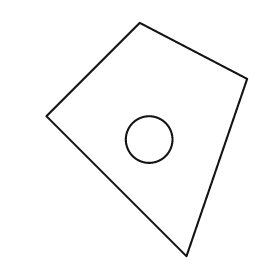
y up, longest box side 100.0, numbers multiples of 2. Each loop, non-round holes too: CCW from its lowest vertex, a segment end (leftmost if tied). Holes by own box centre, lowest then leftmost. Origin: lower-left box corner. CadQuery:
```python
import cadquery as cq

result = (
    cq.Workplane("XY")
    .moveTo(60.0, 0.0)
    .lineTo(86.0, 76.0)
    .lineTo(40.0, 100.0)
    .lineTo(0.0, 60.0)
    .close()
    .moveTo(44.0, 50.0)
    .circle(10.0)
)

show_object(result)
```